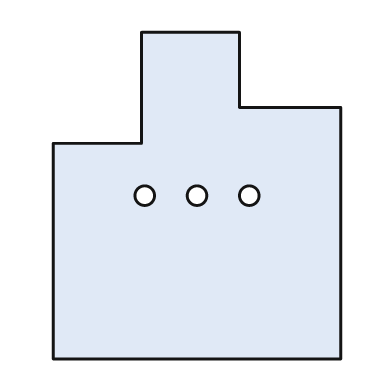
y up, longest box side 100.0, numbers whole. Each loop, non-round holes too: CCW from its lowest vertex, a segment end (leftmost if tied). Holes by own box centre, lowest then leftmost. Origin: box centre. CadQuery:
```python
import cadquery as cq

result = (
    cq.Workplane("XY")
    .moveTo(-44.0, -50.0)
    .lineTo(44.0, -50.0)
    .lineTo(44.0, 27.0)
    .lineTo(13.0, 27.0)
    .lineTo(13.0, 50.0)
    .lineTo(-17.0, 50.0)
    .lineTo(-17.0, 16.0)
    .lineTo(-44.0, 16.0)
    .close()
    .moveTo(-16.0, 0.0)
    .circle(3.0)
    .moveTo(0.0, 0.0)
    .circle(3.0)
    .moveTo(16.0, 0.0)
    .circle(3.0)
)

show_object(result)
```